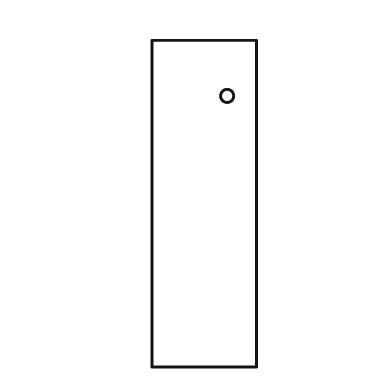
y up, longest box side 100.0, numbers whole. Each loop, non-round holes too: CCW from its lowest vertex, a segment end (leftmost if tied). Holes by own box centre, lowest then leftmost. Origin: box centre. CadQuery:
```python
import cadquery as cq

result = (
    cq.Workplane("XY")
    .moveTo(-16.0, -50.0)
    .lineTo(16.0, -50.0)
    .lineTo(16.0, 50.0)
    .lineTo(-16.0, 50.0)
    .close()
    .moveTo(7.0, 33.0)
    .circle(2.0)
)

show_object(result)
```